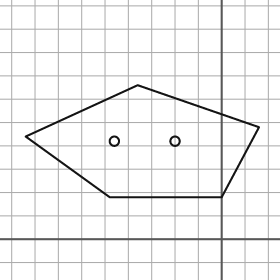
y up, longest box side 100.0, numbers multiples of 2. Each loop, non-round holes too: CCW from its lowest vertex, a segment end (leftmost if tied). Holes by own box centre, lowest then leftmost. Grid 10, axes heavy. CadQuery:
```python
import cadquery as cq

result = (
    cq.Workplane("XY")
    .moveTo(-48.0, 18.0)
    .lineTo(0.0, 18.0)
    .lineTo(16.0, 48.0)
    .lineTo(-36.0, 66.0)
    .lineTo(-84.0, 44.0)
    .close()
    .moveTo(-46.0, 42.0)
    .circle(2.0)
    .moveTo(-20.0, 42.0)
    .circle(2.0)
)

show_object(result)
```